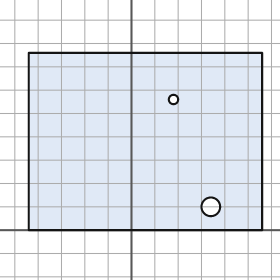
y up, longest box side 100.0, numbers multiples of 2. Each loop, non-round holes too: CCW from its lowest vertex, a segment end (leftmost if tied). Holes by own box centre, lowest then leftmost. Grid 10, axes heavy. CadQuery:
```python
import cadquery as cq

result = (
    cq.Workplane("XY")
    .moveTo(-44.0, 0.0)
    .lineTo(56.0, 0.0)
    .lineTo(56.0, 76.0)
    .lineTo(-44.0, 76.0)
    .close()
    .moveTo(34.0, 10.0)
    .circle(4.0)
    .moveTo(18.0, 56.0)
    .circle(2.0)
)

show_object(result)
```